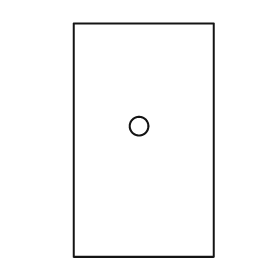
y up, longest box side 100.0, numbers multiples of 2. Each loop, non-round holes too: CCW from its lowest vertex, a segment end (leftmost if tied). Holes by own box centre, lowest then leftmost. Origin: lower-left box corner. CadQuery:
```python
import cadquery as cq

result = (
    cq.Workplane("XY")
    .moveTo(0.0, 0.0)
    .lineTo(60.0, 0.0)
    .lineTo(60.0, 100.0)
    .lineTo(0.0, 100.0)
    .close()
    .moveTo(28.0, 56.0)
    .circle(4.0)
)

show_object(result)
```